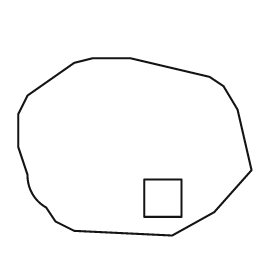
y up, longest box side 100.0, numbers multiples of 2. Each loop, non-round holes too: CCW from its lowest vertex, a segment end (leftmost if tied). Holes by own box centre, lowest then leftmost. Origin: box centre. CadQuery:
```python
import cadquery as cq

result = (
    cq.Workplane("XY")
    .moveTo(16.0, -38.0)
    .lineTo(34.0, -28.0)
    .lineTo(50.0, -10.0)
    .lineTo(44.0, 16.0)
    .lineTo(38.0, 26.0)
    .lineTo(32.0, 30.0)
    .lineTo(-2.0, 38.0)
    .lineTo(-18.0, 38.0)
    .lineTo(-26.0, 36.0)
    .lineTo(-46.0, 22.0)
    .lineTo(-50.0, 14.0)
    .lineTo(-50.0, 0.0)
    .lineTo(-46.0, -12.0)
    .threePointArc((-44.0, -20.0), (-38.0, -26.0))
    .lineTo(-34.0, -32.0)
    .lineTo(-26.0, -36.0)
    .close()
    .moveTo(4.0, -30.0)
    .lineTo(20.0, -30.0)
    .lineTo(20.0, -14.0)
    .lineTo(4.0, -14.0)
    .close()
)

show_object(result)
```